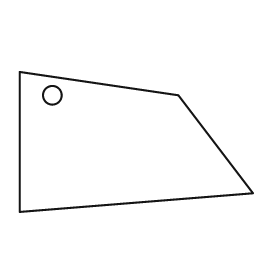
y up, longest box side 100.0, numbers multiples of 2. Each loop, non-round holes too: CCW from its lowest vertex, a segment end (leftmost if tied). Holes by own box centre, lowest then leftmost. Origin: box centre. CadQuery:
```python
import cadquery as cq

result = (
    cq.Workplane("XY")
    .moveTo(-50.0, -30.0)
    .lineTo(50.0, -22.0)
    .lineTo(18.0, 20.0)
    .lineTo(-50.0, 30.0)
    .close()
    .moveTo(-36.0, 20.0)
    .circle(4.0)
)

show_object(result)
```